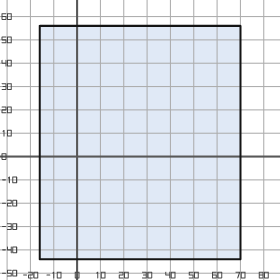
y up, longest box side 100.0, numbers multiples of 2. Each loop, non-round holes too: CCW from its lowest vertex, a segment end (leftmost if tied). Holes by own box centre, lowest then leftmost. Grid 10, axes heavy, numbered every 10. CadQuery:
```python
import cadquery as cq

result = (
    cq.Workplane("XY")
    .moveTo(-16.0, -44.0)
    .lineTo(70.0, -44.0)
    .lineTo(70.0, 56.0)
    .lineTo(-16.0, 56.0)
    .close()
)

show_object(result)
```